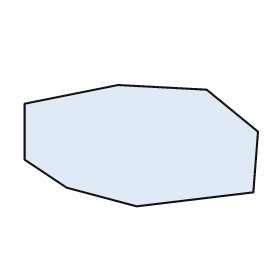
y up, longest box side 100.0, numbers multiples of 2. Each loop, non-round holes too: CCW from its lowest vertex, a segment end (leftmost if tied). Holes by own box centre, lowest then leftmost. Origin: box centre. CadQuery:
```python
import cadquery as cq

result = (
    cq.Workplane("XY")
    .moveTo(-2.0, -26.0)
    .lineTo(48.0, -20.0)
    .lineTo(50.0, 6.0)
    .lineTo(28.0, 24.0)
    .lineTo(-10.0, 26.0)
    .lineTo(-50.0, 18.0)
    .lineTo(-50.0, -6.0)
    .lineTo(-32.0, -18.0)
    .close()
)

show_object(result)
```